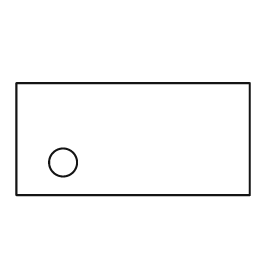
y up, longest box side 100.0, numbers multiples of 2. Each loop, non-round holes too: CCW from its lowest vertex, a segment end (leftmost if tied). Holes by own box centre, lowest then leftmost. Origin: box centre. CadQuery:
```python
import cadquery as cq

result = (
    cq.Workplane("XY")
    .moveTo(-50.0, -24.0)
    .lineTo(50.0, -24.0)
    .lineTo(50.0, 24.0)
    .lineTo(-50.0, 24.0)
    .close()
    .moveTo(-30.0, -10.0)
    .circle(6.0)
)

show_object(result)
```